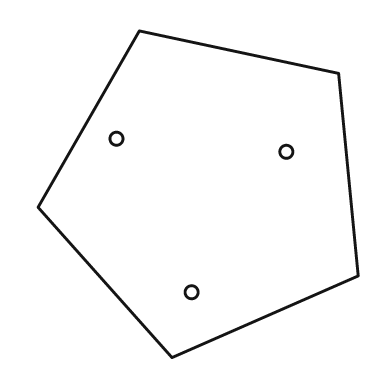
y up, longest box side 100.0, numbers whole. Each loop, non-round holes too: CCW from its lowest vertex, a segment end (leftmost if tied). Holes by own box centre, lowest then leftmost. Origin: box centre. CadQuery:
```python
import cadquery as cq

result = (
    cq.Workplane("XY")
    .moveTo(-8.0, -50.0)
    .lineTo(49.0, -25.0)
    .lineTo(43.0, 37.0)
    .lineTo(-18.0, 50.0)
    .lineTo(-49.0, -4.0)
    .close()
    .moveTo(-2.0, -30.0)
    .circle(2.0)
    .moveTo(27.0, 13.0)
    .circle(2.0)
    .moveTo(-25.0, 17.0)
    .circle(2.0)
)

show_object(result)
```